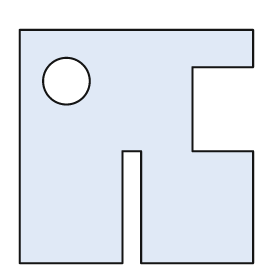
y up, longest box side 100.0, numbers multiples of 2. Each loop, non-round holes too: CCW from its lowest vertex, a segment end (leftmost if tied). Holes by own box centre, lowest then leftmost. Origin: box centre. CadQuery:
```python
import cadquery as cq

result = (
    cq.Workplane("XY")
    .moveTo(-50.0, -50.0)
    .lineTo(-6.0, -50.0)
    .lineTo(-6.0, -2.0)
    .lineTo(2.0, -2.0)
    .lineTo(2.0, -50.0)
    .lineTo(50.0, -50.0)
    .lineTo(50.0, -2.0)
    .lineTo(24.0, -2.0)
    .lineTo(24.0, 34.0)
    .lineTo(50.0, 34.0)
    .lineTo(50.0, 50.0)
    .lineTo(-50.0, 50.0)
    .close()
    .moveTo(-30.0, 28.0)
    .circle(10.0)
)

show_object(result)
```